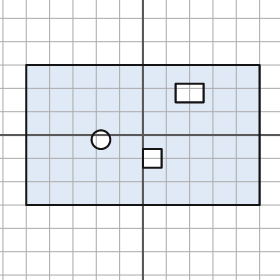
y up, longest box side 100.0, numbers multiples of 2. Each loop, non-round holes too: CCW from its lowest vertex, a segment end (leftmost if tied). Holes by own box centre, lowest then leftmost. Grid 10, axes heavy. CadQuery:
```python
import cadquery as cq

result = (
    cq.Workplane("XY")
    .moveTo(-50.0, -30.0)
    .lineTo(50.0, -30.0)
    .lineTo(50.0, 30.0)
    .lineTo(-50.0, 30.0)
    .close()
    .moveTo(0.0, -14.0)
    .lineTo(8.0, -14.0)
    .lineTo(8.0, -6.0)
    .lineTo(0.0, -6.0)
    .close()
    .moveTo(-18.0, -2.0)
    .circle(4.0)
    .moveTo(14.0, 14.0)
    .lineTo(26.0, 14.0)
    .lineTo(26.0, 22.0)
    .lineTo(14.0, 22.0)
    .close()
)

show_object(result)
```